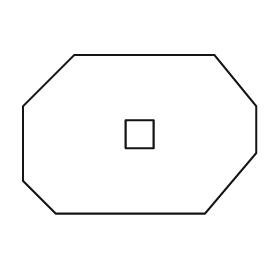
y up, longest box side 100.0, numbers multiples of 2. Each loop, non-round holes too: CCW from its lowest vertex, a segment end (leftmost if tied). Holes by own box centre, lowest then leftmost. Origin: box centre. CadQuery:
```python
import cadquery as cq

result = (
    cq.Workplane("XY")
    .moveTo(-36.0, -34.0)
    .lineTo(28.0, -34.0)
    .lineTo(50.0, -8.0)
    .lineTo(50.0, 12.0)
    .lineTo(32.0, 34.0)
    .lineTo(-28.0, 34.0)
    .lineTo(-50.0, 12.0)
    .lineTo(-50.0, -20.0)
    .close()
    .moveTo(-6.0, -6.0)
    .lineTo(6.0, -6.0)
    .lineTo(6.0, 6.0)
    .lineTo(-6.0, 6.0)
    .close()
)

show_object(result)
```